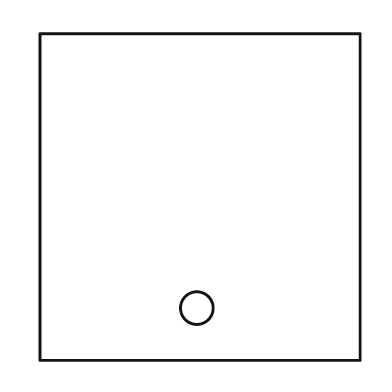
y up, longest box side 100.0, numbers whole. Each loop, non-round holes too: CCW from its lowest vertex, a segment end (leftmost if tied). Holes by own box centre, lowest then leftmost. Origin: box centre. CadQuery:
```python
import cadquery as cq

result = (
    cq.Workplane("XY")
    .moveTo(-49.0, -50.0)
    .lineTo(49.0, -50.0)
    .lineTo(49.0, 50.0)
    .lineTo(-49.0, 50.0)
    .close()
    .moveTo(-1.0, -34.0)
    .circle(5.0)
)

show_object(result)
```